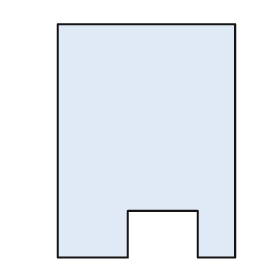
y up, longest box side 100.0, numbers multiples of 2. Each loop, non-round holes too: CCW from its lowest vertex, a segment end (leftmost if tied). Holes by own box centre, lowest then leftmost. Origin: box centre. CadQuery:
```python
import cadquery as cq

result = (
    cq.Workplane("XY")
    .moveTo(-38.0, -50.0)
    .lineTo(-8.0, -50.0)
    .lineTo(-8.0, -30.0)
    .lineTo(22.0, -30.0)
    .lineTo(22.0, -50.0)
    .lineTo(38.0, -50.0)
    .lineTo(38.0, 50.0)
    .lineTo(-38.0, 50.0)
    .close()
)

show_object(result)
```